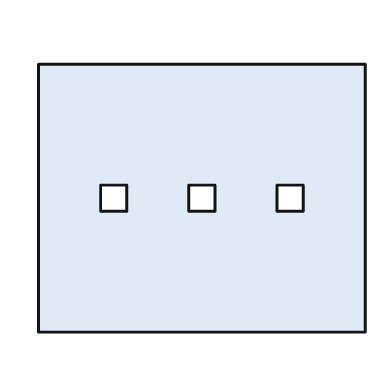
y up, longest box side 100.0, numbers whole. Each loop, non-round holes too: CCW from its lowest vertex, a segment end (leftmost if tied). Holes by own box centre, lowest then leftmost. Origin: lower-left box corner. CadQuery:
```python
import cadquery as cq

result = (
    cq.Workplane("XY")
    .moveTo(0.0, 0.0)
    .lineTo(100.0, 0.0)
    .lineTo(100.0, 82.0)
    .lineTo(0.0, 82.0)
    .close()
    .moveTo(19.0, 37.0)
    .lineTo(27.0, 37.0)
    .lineTo(27.0, 45.0)
    .lineTo(19.0, 45.0)
    .close()
    .moveTo(46.0, 37.0)
    .lineTo(54.0, 37.0)
    .lineTo(54.0, 45.0)
    .lineTo(46.0, 45.0)
    .close()
    .moveTo(73.0, 37.0)
    .lineTo(81.0, 37.0)
    .lineTo(81.0, 45.0)
    .lineTo(73.0, 45.0)
    .close()
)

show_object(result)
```